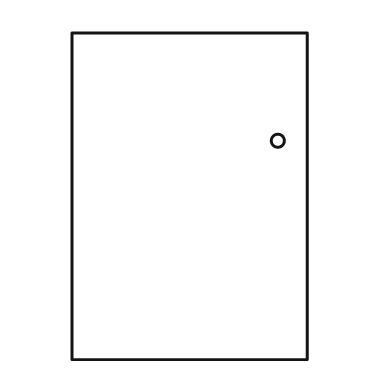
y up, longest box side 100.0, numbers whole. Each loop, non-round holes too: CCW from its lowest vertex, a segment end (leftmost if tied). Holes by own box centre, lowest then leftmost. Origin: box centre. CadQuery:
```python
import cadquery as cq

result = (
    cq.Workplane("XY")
    .moveTo(-36.0, -50.0)
    .lineTo(36.0, -50.0)
    .lineTo(36.0, 50.0)
    .lineTo(-36.0, 50.0)
    .close()
    .moveTo(27.0, 17.0)
    .circle(2.0)
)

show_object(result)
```